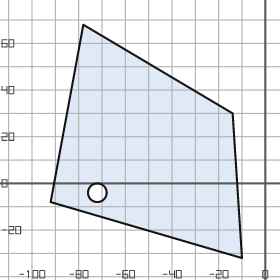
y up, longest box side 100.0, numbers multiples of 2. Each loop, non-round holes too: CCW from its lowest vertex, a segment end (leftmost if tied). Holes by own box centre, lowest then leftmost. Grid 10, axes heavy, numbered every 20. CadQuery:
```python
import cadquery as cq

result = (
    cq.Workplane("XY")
    .moveTo(-10.0, -32.0)
    .lineTo(-14.0, 30.0)
    .lineTo(-78.0, 68.0)
    .lineTo(-92.0, -8.0)
    .close()
    .moveTo(-72.0, -4.0)
    .circle(4.0)
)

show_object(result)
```